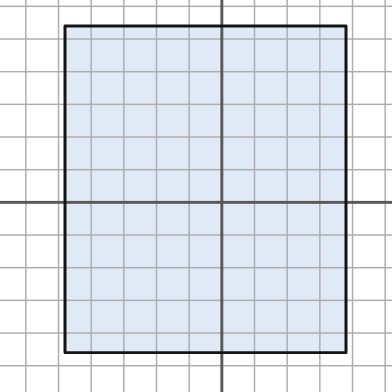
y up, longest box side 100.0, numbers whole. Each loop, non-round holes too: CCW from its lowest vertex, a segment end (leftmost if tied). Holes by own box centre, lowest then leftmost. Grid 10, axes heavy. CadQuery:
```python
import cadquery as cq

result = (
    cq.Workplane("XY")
    .moveTo(-48.0, -46.0)
    .lineTo(38.0, -46.0)
    .lineTo(38.0, 54.0)
    .lineTo(-48.0, 54.0)
    .close()
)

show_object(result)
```